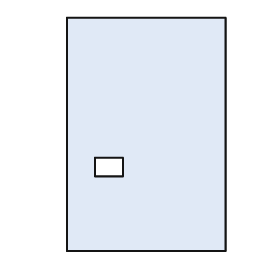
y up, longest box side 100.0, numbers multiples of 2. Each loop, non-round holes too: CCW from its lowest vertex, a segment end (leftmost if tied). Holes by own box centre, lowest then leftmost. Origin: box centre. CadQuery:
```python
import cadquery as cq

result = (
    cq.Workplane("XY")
    .moveTo(-34.0, -50.0)
    .lineTo(34.0, -50.0)
    .lineTo(34.0, 50.0)
    .lineTo(-34.0, 50.0)
    .close()
    .moveTo(-22.0, -18.0)
    .lineTo(-10.0, -18.0)
    .lineTo(-10.0, -10.0)
    .lineTo(-22.0, -10.0)
    .close()
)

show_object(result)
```